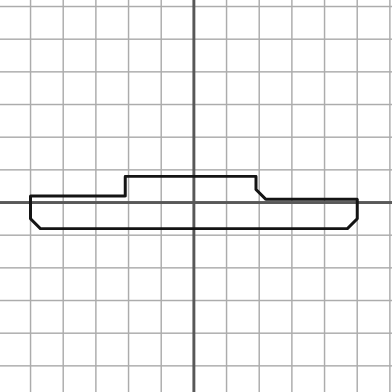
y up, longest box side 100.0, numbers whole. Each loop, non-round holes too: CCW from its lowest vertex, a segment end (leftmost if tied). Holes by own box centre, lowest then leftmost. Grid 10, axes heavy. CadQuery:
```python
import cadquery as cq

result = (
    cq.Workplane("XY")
    .moveTo(-47.0, -8.0)
    .lineTo(47.0, -8.0)
    .lineTo(50.0, -5.0)
    .lineTo(50.0, 1.0)
    .lineTo(22.0, 1.0)
    .lineTo(19.0, 4.0)
    .lineTo(19.0, 8.0)
    .lineTo(-21.0, 8.0)
    .lineTo(-21.0, 2.0)
    .lineTo(-50.0, 2.0)
    .lineTo(-50.0, -5.0)
    .close()
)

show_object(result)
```